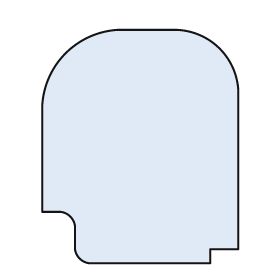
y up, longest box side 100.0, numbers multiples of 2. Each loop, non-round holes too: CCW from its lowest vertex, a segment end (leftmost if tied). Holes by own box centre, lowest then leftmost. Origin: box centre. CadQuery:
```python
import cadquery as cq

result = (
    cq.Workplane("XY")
    .moveTo(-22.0, -50.0)
    .lineTo(30.0, -50.0)
    .lineTo(30.0, -44.0)
    .lineTo(42.0, -44.0)
    .lineTo(42.0, 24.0)
    .threePointArc((34.0, 42.0), (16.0, 50.0))
    .lineTo(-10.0, 50.0)
    .threePointArc((-32.0, 40.0), (-42.0, 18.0))
    .lineTo(-42.0, -28.0)
    .lineTo(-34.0, -28.0)
    .threePointArc((-30.0, -30.0), (-28.0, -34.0))
    .lineTo(-28.0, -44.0)
    .threePointArc((-26.0, -48.0), (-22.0, -50.0))
    .close()
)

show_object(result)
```